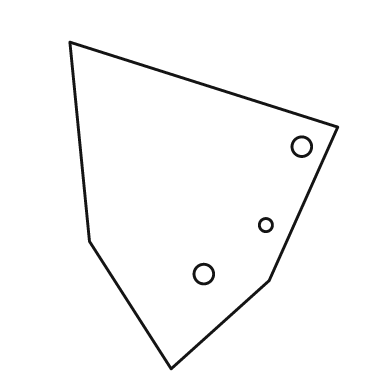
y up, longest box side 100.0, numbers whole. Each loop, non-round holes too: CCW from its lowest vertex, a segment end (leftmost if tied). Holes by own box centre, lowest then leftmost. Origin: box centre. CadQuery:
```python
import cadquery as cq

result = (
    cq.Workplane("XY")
    .moveTo(-10.0, -50.0)
    .lineTo(20.0, -23.0)
    .lineTo(41.0, 24.0)
    .lineTo(-41.0, 50.0)
    .lineTo(-35.0, -11.0)
    .close()
    .moveTo(0.0, -21.0)
    .circle(3.0)
    .moveTo(19.0, -6.0)
    .circle(2.0)
    .moveTo(30.0, 18.0)
    .circle(3.0)
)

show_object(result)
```